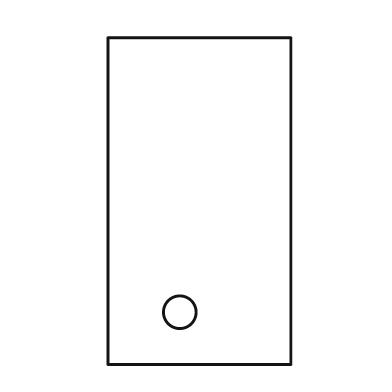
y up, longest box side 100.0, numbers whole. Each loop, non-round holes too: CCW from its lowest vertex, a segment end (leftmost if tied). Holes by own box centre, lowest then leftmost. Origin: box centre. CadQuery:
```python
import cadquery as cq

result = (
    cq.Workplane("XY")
    .moveTo(-28.0, -50.0)
    .lineTo(28.0, -50.0)
    .lineTo(28.0, 50.0)
    .lineTo(-28.0, 50.0)
    .close()
    .moveTo(-6.0, -34.0)
    .circle(5.0)
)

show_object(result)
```